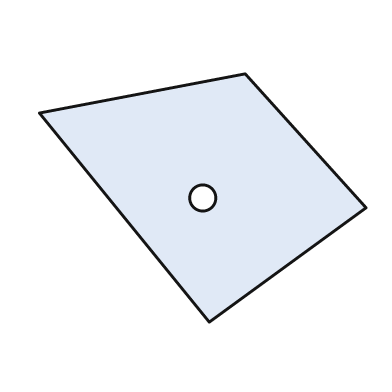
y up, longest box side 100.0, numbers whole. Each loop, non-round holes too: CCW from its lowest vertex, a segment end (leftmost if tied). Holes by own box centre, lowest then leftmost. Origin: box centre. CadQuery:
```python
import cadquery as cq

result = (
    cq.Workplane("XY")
    .moveTo(2.0, -38.0)
    .lineTo(50.0, -3.0)
    .lineTo(13.0, 38.0)
    .lineTo(-50.0, 26.0)
    .close()
    .moveTo(0.0, 0.0)
    .circle(4.0)
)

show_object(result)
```